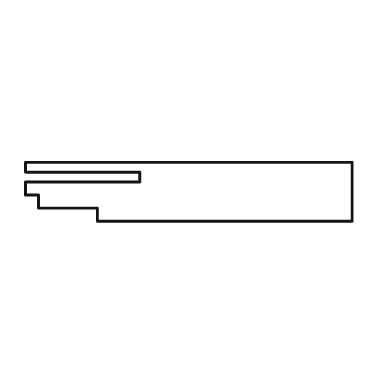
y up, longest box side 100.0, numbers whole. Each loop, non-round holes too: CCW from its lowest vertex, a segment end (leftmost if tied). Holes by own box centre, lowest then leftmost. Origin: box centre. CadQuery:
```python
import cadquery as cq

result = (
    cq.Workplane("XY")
    .moveTo(-28.0, -9.0)
    .lineTo(50.0, -9.0)
    .lineTo(50.0, 9.0)
    .lineTo(-50.0, 9.0)
    .lineTo(-50.0, 6.0)
    .lineTo(-15.0, 6.0)
    .lineTo(-15.0, 3.0)
    .lineTo(-50.0, 3.0)
    .lineTo(-50.0, -1.0)
    .lineTo(-46.0, -1.0)
    .lineTo(-46.0, -5.0)
    .lineTo(-28.0, -5.0)
    .close()
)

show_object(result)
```